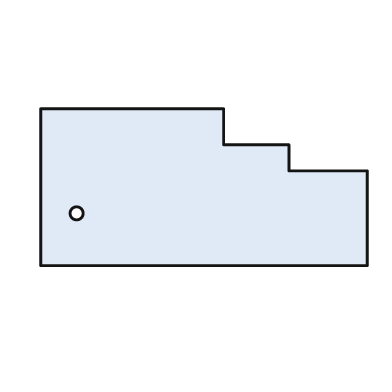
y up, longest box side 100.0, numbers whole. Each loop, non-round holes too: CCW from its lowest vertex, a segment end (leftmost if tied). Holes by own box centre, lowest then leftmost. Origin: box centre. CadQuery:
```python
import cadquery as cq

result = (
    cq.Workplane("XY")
    .moveTo(-50.0, -24.0)
    .lineTo(50.0, -24.0)
    .lineTo(50.0, 5.0)
    .lineTo(26.0, 5.0)
    .lineTo(26.0, 13.0)
    .lineTo(6.0, 13.0)
    .lineTo(6.0, 24.0)
    .lineTo(-50.0, 24.0)
    .close()
    .moveTo(-39.0, -8.0)
    .circle(2.0)
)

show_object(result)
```